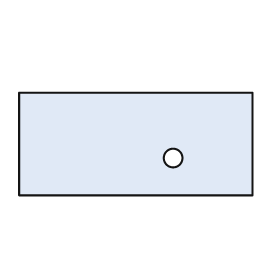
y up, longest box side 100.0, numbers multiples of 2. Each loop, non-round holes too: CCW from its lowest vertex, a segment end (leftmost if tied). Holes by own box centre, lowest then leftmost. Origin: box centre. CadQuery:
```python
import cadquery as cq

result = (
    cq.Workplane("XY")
    .moveTo(-50.0, -22.0)
    .lineTo(50.0, -22.0)
    .lineTo(50.0, 22.0)
    .lineTo(-50.0, 22.0)
    .close()
    .moveTo(16.0, -6.0)
    .circle(4.0)
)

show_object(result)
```